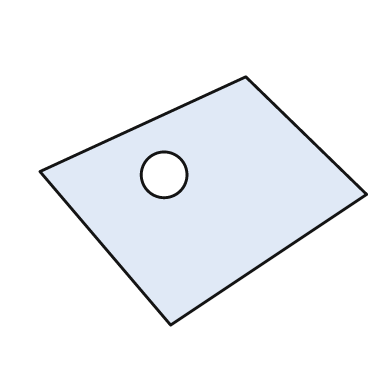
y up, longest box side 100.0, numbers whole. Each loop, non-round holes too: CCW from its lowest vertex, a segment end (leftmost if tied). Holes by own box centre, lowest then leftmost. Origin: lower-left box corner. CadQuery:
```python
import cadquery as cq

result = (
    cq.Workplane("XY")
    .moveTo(40.0, 0.0)
    .lineTo(100.0, 40.0)
    .lineTo(63.0, 76.0)
    .lineTo(0.0, 47.0)
    .close()
    .moveTo(38.0, 46.0)
    .circle(7.0)
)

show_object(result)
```